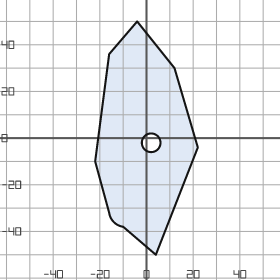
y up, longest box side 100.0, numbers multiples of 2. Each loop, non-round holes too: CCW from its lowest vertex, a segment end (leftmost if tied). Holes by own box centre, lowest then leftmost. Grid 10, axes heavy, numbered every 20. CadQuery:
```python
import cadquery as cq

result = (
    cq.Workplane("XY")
    .moveTo(4.0, -50.0)
    .lineTo(22.0, -4.0)
    .lineTo(12.0, 30.0)
    .lineTo(-4.0, 50.0)
    .lineTo(-16.0, 36.0)
    .lineTo(-22.0, -10.0)
    .lineTo(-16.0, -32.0)
    .threePointArc((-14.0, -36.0), (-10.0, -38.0))
    .close()
    .moveTo(2.0, -2.0)
    .circle(4.0)
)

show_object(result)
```